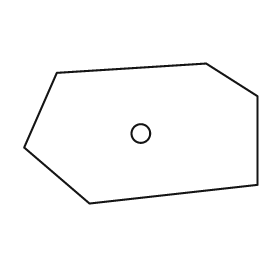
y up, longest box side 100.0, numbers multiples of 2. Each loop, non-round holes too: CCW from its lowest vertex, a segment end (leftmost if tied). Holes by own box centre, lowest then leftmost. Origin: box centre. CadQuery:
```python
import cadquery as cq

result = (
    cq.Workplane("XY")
    .moveTo(-22.0, -30.0)
    .lineTo(50.0, -22.0)
    .lineTo(50.0, 16.0)
    .lineTo(28.0, 30.0)
    .lineTo(-36.0, 26.0)
    .lineTo(-50.0, -6.0)
    .close()
    .moveTo(0.0, 0.0)
    .circle(4.0)
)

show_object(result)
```